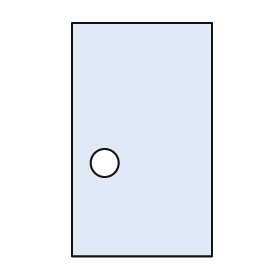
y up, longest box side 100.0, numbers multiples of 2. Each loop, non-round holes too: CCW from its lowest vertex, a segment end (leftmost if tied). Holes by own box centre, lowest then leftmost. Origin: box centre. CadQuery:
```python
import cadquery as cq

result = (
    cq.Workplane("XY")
    .moveTo(-30.0, -50.0)
    .lineTo(30.0, -50.0)
    .lineTo(30.0, 50.0)
    .lineTo(-30.0, 50.0)
    .close()
    .moveTo(-16.0, -10.0)
    .circle(6.0)
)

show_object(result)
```